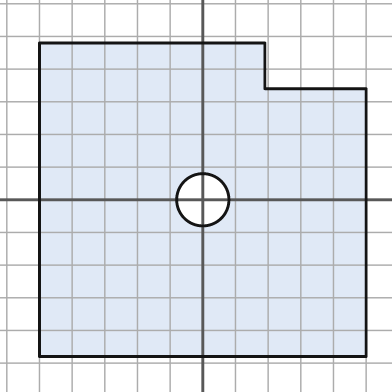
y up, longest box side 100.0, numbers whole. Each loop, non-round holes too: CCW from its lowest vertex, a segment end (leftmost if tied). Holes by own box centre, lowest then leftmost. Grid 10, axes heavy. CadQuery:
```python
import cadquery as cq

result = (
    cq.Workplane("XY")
    .moveTo(-50.0, -48.0)
    .lineTo(50.0, -48.0)
    .lineTo(50.0, 34.0)
    .lineTo(19.0, 34.0)
    .lineTo(19.0, 48.0)
    .lineTo(-50.0, 48.0)
    .close()
    .moveTo(0.0, 0.0)
    .circle(8.0)
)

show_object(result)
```